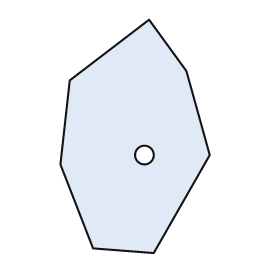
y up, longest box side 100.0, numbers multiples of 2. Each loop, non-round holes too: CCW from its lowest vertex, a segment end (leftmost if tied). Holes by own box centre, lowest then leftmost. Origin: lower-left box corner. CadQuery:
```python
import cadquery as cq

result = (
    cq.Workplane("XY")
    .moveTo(40.0, 0.0)
    .lineTo(64.0, 42.0)
    .lineTo(54.0, 78.0)
    .lineTo(38.0, 100.0)
    .lineTo(4.0, 74.0)
    .lineTo(0.0, 38.0)
    .lineTo(14.0, 2.0)
    .close()
    .moveTo(36.0, 42.0)
    .circle(4.0)
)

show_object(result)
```